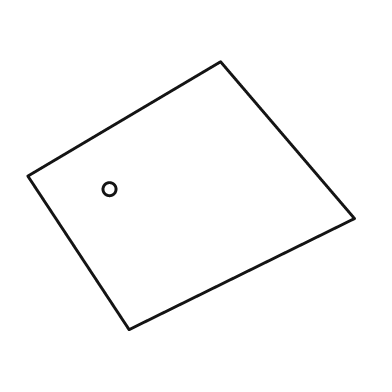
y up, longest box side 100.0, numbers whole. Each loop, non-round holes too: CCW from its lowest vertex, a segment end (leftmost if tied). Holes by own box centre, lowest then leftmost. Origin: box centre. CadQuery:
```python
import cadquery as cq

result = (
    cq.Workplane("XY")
    .moveTo(-19.0, -41.0)
    .lineTo(50.0, -7.0)
    .lineTo(9.0, 41.0)
    .lineTo(-50.0, 6.0)
    .close()
    .moveTo(-25.0, 2.0)
    .circle(2.0)
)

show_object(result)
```